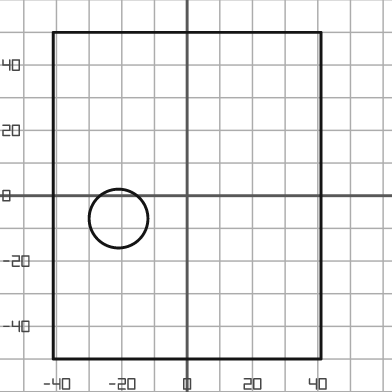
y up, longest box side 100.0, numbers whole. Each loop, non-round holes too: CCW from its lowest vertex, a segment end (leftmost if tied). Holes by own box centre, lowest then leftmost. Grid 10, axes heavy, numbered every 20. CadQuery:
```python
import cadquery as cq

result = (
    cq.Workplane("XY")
    .moveTo(-41.0, -50.0)
    .lineTo(41.0, -50.0)
    .lineTo(41.0, 50.0)
    .lineTo(-41.0, 50.0)
    .close()
    .moveTo(-21.0, -7.0)
    .circle(9.0)
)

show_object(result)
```